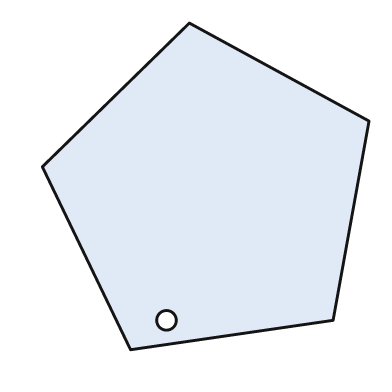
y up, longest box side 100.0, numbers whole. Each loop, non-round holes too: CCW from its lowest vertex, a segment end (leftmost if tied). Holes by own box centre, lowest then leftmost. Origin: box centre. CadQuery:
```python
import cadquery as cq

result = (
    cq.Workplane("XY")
    .moveTo(-23.0, -50.0)
    .lineTo(39.0, -41.0)
    .lineTo(50.0, 20.0)
    .lineTo(-5.0, 50.0)
    .lineTo(-50.0, 6.0)
    .close()
    .moveTo(-12.0, -41.0)
    .circle(3.0)
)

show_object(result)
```